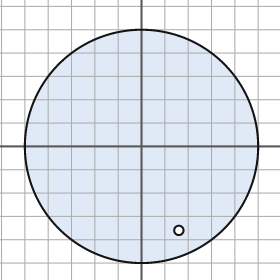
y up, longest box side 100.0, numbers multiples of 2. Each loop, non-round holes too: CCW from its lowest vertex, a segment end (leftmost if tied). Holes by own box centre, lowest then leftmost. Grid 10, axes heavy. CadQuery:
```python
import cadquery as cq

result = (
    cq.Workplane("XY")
    .moveTo(0.0, 0.0)
    .circle(50.0)
    .moveTo(16.0, -36.0)
    .circle(2.0)
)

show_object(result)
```